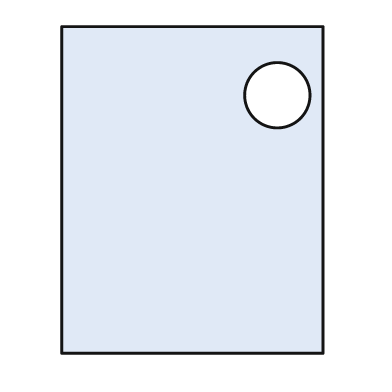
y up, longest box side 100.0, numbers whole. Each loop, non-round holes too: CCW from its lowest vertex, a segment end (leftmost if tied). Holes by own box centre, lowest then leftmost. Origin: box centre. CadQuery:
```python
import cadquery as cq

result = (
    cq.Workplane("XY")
    .moveTo(-40.0, -50.0)
    .lineTo(40.0, -50.0)
    .lineTo(40.0, 50.0)
    .lineTo(-40.0, 50.0)
    .close()
    .moveTo(26.0, 29.0)
    .circle(10.0)
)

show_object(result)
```